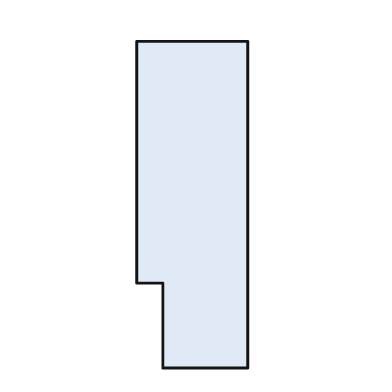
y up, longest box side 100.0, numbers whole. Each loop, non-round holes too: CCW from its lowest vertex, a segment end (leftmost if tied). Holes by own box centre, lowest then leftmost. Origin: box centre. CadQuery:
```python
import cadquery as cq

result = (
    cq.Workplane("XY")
    .moveTo(-9.0, -50.0)
    .lineTo(17.0, -50.0)
    .lineTo(17.0, 50.0)
    .lineTo(-17.0, 50.0)
    .lineTo(-17.0, -24.0)
    .lineTo(-9.0, -24.0)
    .close()
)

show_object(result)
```